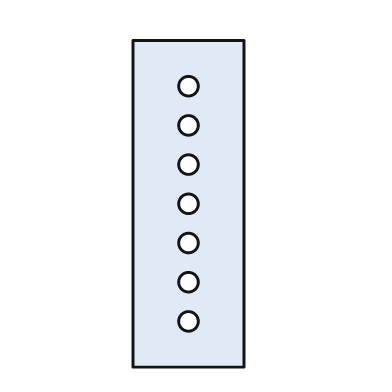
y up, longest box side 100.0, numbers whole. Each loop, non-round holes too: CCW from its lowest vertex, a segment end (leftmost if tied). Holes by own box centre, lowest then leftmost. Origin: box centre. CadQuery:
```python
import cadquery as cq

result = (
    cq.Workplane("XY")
    .moveTo(-17.0, -50.0)
    .lineTo(17.0, -50.0)
    .lineTo(17.0, 50.0)
    .lineTo(-17.0, 50.0)
    .close()
    .moveTo(0.0, -36.0)
    .circle(3.0)
    .moveTo(0.0, -24.0)
    .circle(3.0)
    .moveTo(0.0, -12.0)
    .circle(3.0)
    .moveTo(0.0, 0.0)
    .circle(3.0)
    .moveTo(0.0, 12.0)
    .circle(3.0)
    .moveTo(0.0, 24.0)
    .circle(3.0)
    .moveTo(0.0, 36.0)
    .circle(3.0)
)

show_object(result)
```